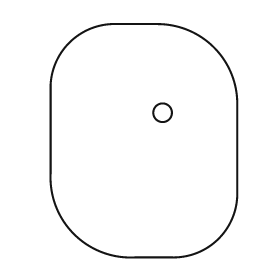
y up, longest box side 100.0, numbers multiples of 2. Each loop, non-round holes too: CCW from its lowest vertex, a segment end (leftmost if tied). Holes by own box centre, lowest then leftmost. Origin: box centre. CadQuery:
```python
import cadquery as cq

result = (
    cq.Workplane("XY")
    .moveTo(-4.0, -50.0)
    .lineTo(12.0, -50.0)
    .threePointArc((32.0, -42.0), (40.0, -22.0))
    .lineTo(40.0, 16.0)
    .threePointArc((30.0, 40.0), (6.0, 50.0))
    .lineTo(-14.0, 50.0)
    .threePointArc((-32.0, 42.0), (-40.0, 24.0))
    .lineTo(-40.0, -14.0)
    .threePointArc((-30.0, -40.0), (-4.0, -50.0))
    .close()
    .moveTo(8.0, 12.0)
    .circle(4.0)
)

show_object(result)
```